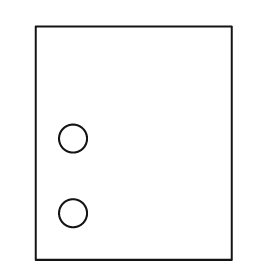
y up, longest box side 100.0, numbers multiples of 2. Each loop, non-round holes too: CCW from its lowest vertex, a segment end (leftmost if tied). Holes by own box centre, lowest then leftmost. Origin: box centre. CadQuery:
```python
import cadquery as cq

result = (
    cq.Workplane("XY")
    .moveTo(-42.0, -50.0)
    .lineTo(42.0, -50.0)
    .lineTo(42.0, 50.0)
    .lineTo(-42.0, 50.0)
    .close()
    .moveTo(-26.0, -30.0)
    .circle(6.0)
    .moveTo(-26.0, 2.0)
    .circle(6.0)
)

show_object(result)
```